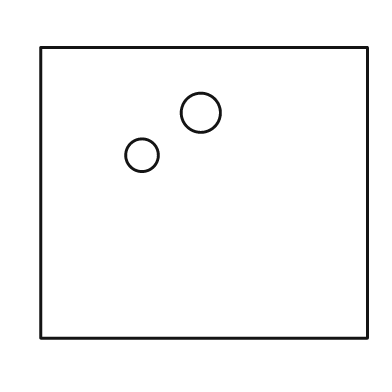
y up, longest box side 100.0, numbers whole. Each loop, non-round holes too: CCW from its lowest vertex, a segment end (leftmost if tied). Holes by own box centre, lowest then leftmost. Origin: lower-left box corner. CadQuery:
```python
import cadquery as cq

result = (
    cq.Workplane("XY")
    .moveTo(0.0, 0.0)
    .lineTo(100.0, 0.0)
    .lineTo(100.0, 89.0)
    .lineTo(0.0, 89.0)
    .close()
    .moveTo(31.0, 56.0)
    .circle(5.0)
    .moveTo(49.0, 69.0)
    .circle(6.0)
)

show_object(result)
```